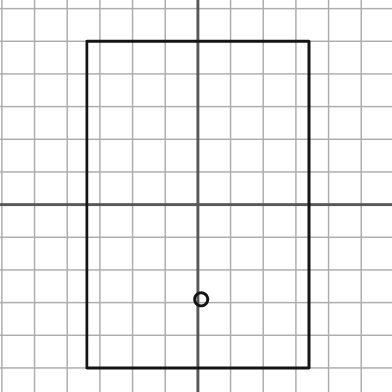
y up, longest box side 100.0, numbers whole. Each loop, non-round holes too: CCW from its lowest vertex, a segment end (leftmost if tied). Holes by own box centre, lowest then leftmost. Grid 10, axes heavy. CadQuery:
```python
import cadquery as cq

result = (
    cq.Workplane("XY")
    .moveTo(-34.0, -50.0)
    .lineTo(34.0, -50.0)
    .lineTo(34.0, 50.0)
    .lineTo(-34.0, 50.0)
    .close()
    .moveTo(1.0, -29.0)
    .circle(2.0)
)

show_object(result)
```